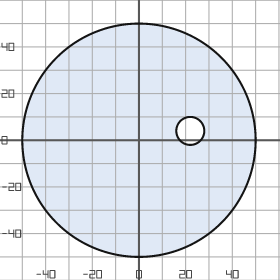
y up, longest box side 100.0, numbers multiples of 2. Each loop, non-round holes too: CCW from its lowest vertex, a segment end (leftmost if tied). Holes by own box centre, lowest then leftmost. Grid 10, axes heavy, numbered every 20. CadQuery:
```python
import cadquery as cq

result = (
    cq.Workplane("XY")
    .moveTo(0.0, 0.0)
    .circle(50.0)
    .moveTo(22.0, 4.0)
    .circle(6.0)
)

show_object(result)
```